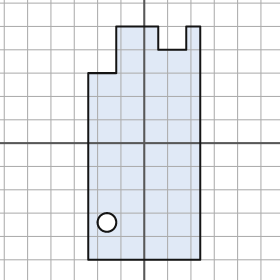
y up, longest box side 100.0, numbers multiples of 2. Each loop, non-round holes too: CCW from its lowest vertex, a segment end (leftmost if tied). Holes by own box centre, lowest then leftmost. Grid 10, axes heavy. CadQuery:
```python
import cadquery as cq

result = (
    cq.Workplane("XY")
    .moveTo(-24.0, -50.0)
    .lineTo(24.0, -50.0)
    .lineTo(24.0, 50.0)
    .lineTo(18.0, 50.0)
    .lineTo(18.0, 40.0)
    .lineTo(6.0, 40.0)
    .lineTo(6.0, 50.0)
    .lineTo(-12.0, 50.0)
    .lineTo(-12.0, 30.0)
    .lineTo(-24.0, 30.0)
    .close()
    .moveTo(-16.0, -34.0)
    .circle(4.0)
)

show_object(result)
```